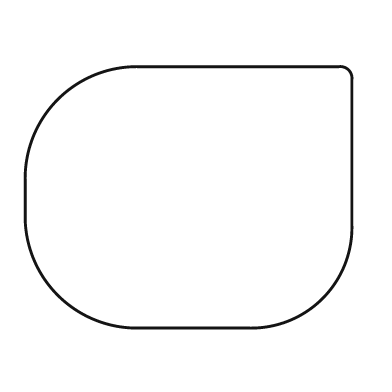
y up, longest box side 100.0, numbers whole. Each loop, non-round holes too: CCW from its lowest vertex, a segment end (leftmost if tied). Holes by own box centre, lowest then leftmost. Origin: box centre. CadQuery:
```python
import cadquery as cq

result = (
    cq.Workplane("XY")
    .moveTo(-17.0, -40.0)
    .lineTo(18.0, -40.0)
    .threePointArc((41.0, -31.0), (50.0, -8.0))
    .lineTo(50.0, 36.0)
    .threePointArc((49.0, 39.0), (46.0, 40.0))
    .lineTo(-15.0, 40.0)
    .threePointArc((-40.0, 30.0), (-50.0, 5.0))
    .lineTo(-50.0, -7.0)
    .threePointArc((-40.0, -30.0), (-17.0, -40.0))
    .close()
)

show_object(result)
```